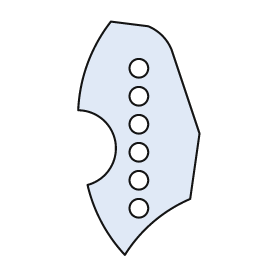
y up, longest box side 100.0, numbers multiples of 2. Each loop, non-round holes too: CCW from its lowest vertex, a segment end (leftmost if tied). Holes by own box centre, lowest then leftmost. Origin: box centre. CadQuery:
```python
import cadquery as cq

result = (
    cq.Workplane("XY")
    .moveTo(-6.0, -50.0)
    .threePointArc((6.0, -36.0), (22.0, -26.0))
    .lineTo(26.0, 2.0)
    .lineTo(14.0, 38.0)
    .threePointArc((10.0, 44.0), (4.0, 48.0))
    .lineTo(-12.0, 50.0)
    .threePointArc((-22.0, 32.0), (-26.0, 12.0))
    .threePointArc((-10.0, -2.0), (-22.0, -20.0))
    .threePointArc((-16.0, -36.0), (-6.0, -50.0))
    .close()
    .moveTo(0.0, -30.0)
    .circle(4.0)
    .moveTo(0.0, -18.0)
    .circle(4.0)
    .moveTo(0.0, -6.0)
    .circle(4.0)
    .moveTo(0.0, 6.0)
    .circle(4.0)
    .moveTo(0.0, 18.0)
    .circle(4.0)
    .moveTo(0.0, 30.0)
    .circle(4.0)
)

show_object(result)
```